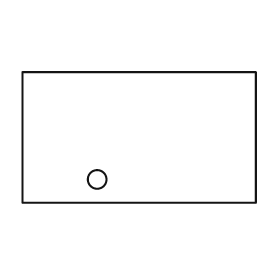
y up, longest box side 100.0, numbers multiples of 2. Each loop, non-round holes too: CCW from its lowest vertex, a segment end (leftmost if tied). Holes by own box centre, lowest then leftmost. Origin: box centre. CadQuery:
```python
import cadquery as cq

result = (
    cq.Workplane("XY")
    .moveTo(-50.0, -28.0)
    .lineTo(50.0, -28.0)
    .lineTo(50.0, 28.0)
    .lineTo(-50.0, 28.0)
    .close()
    .moveTo(-18.0, -18.0)
    .circle(4.0)
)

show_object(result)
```